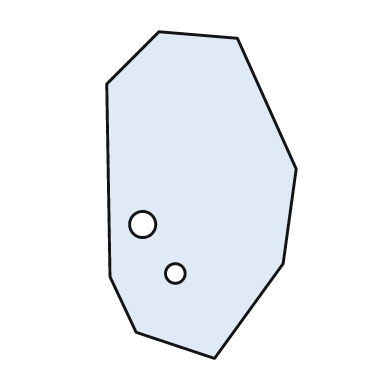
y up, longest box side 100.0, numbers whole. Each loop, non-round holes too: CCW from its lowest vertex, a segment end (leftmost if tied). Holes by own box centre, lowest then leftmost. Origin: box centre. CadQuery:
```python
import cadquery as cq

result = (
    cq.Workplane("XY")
    .moveTo(4.0, -50.0)
    .lineTo(25.0, -21.0)
    .lineTo(29.0, 8.0)
    .lineTo(11.0, 48.0)
    .lineTo(-13.0, 50.0)
    .lineTo(-29.0, 34.0)
    .lineTo(-28.0, -25.0)
    .lineTo(-20.0, -42.0)
    .close()
    .moveTo(-8.0, -24.0)
    .circle(3.0)
    .moveTo(-18.0, -9.0)
    .circle(4.0)
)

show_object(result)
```